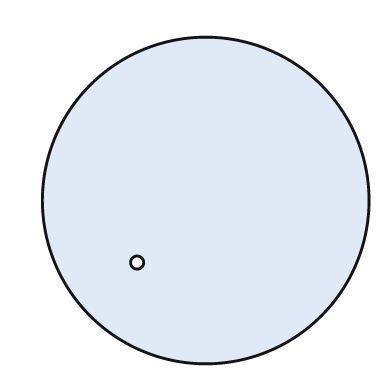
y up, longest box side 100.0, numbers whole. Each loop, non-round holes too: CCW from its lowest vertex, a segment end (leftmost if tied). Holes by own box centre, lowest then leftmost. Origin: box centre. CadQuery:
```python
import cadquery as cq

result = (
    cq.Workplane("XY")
    .moveTo(0.0, 0.0)
    .circle(50.0)
    .moveTo(-21.0, -19.0)
    .circle(2.0)
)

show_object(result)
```